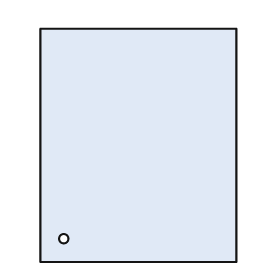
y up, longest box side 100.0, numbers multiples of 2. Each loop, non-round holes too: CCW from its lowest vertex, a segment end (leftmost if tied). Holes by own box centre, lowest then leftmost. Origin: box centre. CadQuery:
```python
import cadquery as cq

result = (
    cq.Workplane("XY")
    .moveTo(-42.0, -50.0)
    .lineTo(42.0, -50.0)
    .lineTo(42.0, 50.0)
    .lineTo(-42.0, 50.0)
    .close()
    .moveTo(-32.0, -40.0)
    .circle(2.0)
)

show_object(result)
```